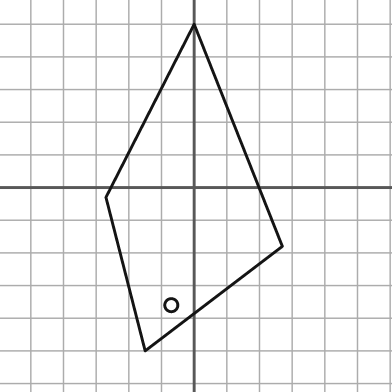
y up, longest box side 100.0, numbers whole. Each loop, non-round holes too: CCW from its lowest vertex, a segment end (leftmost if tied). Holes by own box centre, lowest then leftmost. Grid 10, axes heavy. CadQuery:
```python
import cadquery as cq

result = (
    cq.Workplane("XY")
    .moveTo(-15.0, -50.0)
    .lineTo(27.0, -18.0)
    .lineTo(0.0, 50.0)
    .lineTo(-27.0, -3.0)
    .close()
    .moveTo(-7.0, -36.0)
    .circle(2.0)
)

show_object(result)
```